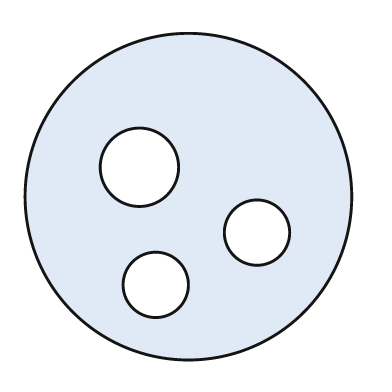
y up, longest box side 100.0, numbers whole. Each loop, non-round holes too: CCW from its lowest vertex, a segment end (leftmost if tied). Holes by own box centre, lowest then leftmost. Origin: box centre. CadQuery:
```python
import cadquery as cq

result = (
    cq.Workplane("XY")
    .moveTo(0.0, 0.0)
    .circle(50.0)
    .moveTo(-10.0, -27.0)
    .circle(10.0)
    .moveTo(21.0, -11.0)
    .circle(10.0)
    .moveTo(-15.0, 9.0)
    .circle(12.0)
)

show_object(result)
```